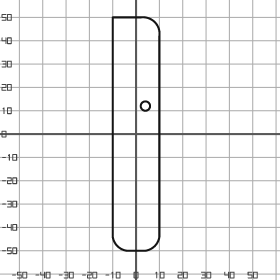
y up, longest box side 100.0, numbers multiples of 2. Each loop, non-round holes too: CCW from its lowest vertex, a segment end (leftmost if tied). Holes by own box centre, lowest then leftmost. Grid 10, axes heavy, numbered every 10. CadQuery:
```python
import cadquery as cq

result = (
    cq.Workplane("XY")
    .moveTo(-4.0, -50.0)
    .lineTo(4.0, -50.0)
    .threePointArc((8.0, -48.0), (10.0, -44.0))
    .lineTo(10.0, 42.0)
    .threePointArc((8.0, 48.0), (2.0, 50.0))
    .lineTo(-10.0, 50.0)
    .lineTo(-10.0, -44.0)
    .threePointArc((-8.0, -48.0), (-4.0, -50.0))
    .close()
    .moveTo(4.0, 12.0)
    .circle(2.0)
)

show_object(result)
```